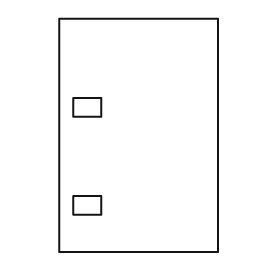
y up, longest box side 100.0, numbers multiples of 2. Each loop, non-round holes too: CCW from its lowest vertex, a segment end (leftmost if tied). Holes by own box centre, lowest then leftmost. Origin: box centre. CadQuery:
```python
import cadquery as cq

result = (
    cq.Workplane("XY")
    .moveTo(-34.0, -50.0)
    .lineTo(34.0, -50.0)
    .lineTo(34.0, 50.0)
    .lineTo(-34.0, 50.0)
    .close()
    .moveTo(-28.0, -34.0)
    .lineTo(-16.0, -34.0)
    .lineTo(-16.0, -26.0)
    .lineTo(-28.0, -26.0)
    .close()
    .moveTo(-28.0, 8.0)
    .lineTo(-16.0, 8.0)
    .lineTo(-16.0, 16.0)
    .lineTo(-28.0, 16.0)
    .close()
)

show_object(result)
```